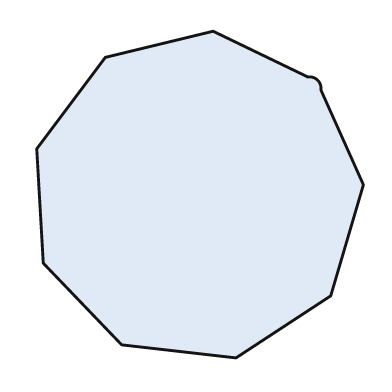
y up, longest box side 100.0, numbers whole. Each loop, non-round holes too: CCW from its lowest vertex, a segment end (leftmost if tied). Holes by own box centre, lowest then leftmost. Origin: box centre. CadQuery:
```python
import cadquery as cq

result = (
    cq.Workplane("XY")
    .moveTo(11.0, -50.0)
    .lineTo(40.0, -31.0)
    .lineTo(50.0, 3.0)
    .lineTo(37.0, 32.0)
    .threePointArc((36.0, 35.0), (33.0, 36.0))
    .lineTo(4.0, 50.0)
    .lineTo(-29.0, 42.0)
    .lineTo(-50.0, 14.0)
    .lineTo(-48.0, -21.0)
    .lineTo(-24.0, -46.0)
    .close()
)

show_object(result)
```